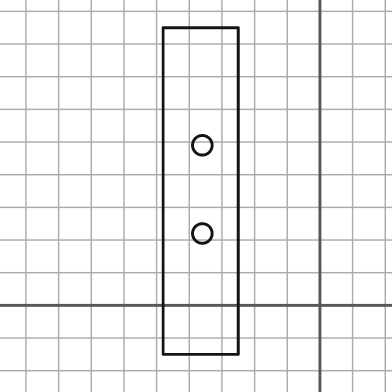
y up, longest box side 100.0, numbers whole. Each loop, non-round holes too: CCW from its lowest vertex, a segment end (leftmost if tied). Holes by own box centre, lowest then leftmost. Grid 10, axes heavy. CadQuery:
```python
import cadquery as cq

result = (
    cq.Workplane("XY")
    .moveTo(-48.0, -15.0)
    .lineTo(-25.0, -15.0)
    .lineTo(-25.0, 85.0)
    .lineTo(-48.0, 85.0)
    .close()
    .moveTo(-36.0, 22.0)
    .circle(3.0)
    .moveTo(-36.0, 49.0)
    .circle(3.0)
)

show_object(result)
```